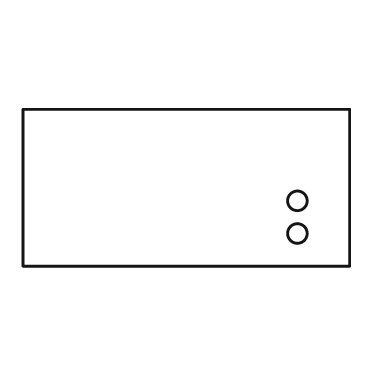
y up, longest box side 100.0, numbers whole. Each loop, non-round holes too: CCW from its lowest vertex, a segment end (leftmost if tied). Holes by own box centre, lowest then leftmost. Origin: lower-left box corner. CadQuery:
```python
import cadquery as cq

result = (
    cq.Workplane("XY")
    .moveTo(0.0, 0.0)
    .lineTo(100.0, 0.0)
    .lineTo(100.0, 48.0)
    .lineTo(0.0, 48.0)
    .close()
    .moveTo(84.0, 10.0)
    .circle(3.0)
    .moveTo(84.0, 20.0)
    .circle(3.0)
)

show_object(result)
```